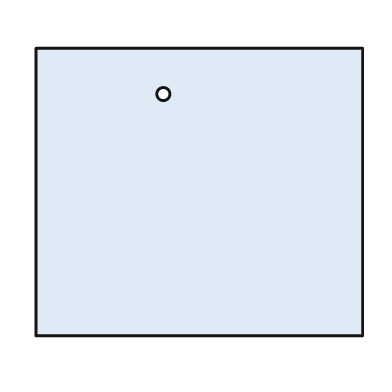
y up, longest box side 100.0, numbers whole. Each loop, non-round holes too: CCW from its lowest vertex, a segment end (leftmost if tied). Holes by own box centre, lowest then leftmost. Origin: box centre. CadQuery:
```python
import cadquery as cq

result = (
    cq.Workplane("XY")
    .moveTo(-50.0, -44.0)
    .lineTo(50.0, -44.0)
    .lineTo(50.0, 44.0)
    .lineTo(-50.0, 44.0)
    .close()
    .moveTo(-11.0, 30.0)
    .circle(2.0)
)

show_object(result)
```